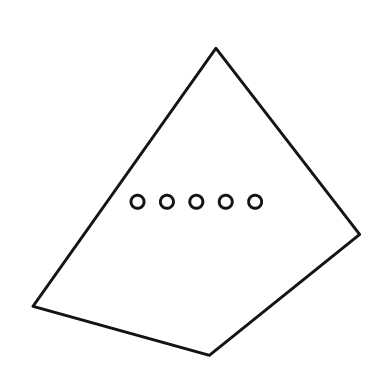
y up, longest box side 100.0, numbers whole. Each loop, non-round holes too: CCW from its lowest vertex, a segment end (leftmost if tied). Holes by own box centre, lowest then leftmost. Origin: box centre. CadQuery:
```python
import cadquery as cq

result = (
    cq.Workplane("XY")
    .moveTo(4.0, -47.0)
    .lineTo(50.0, -10.0)
    .lineTo(6.0, 47.0)
    .lineTo(-50.0, -32.0)
    .close()
    .moveTo(-18.0, 0.0)
    .circle(2.0)
    .moveTo(-9.0, 0.0)
    .circle(2.0)
    .moveTo(0.0, 0.0)
    .circle(2.0)
    .moveTo(9.0, 0.0)
    .circle(2.0)
    .moveTo(18.0, 0.0)
    .circle(2.0)
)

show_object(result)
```